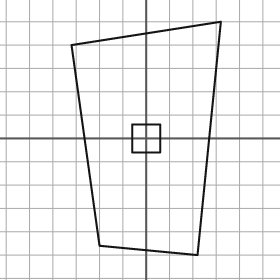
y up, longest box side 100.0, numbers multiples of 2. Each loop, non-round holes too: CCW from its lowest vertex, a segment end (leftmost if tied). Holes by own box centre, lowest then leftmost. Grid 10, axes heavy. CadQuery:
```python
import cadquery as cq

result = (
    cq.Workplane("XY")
    .moveTo(22.0, -50.0)
    .lineTo(32.0, 50.0)
    .lineTo(-32.0, 40.0)
    .lineTo(-20.0, -46.0)
    .close()
    .moveTo(-6.0, -6.0)
    .lineTo(6.0, -6.0)
    .lineTo(6.0, 6.0)
    .lineTo(-6.0, 6.0)
    .close()
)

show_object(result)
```